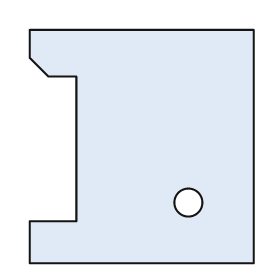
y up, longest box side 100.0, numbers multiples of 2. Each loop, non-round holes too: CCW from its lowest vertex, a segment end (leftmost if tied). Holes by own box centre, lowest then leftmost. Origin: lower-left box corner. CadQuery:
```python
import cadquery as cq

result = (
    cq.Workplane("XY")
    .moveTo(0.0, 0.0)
    .lineTo(96.0, 0.0)
    .lineTo(96.0, 100.0)
    .lineTo(0.0, 100.0)
    .lineTo(0.0, 88.0)
    .lineTo(8.0, 80.0)
    .lineTo(20.0, 80.0)
    .lineTo(20.0, 18.0)
    .lineTo(0.0, 18.0)
    .close()
    .moveTo(68.0, 26.0)
    .circle(6.0)
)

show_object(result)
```